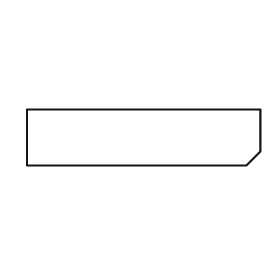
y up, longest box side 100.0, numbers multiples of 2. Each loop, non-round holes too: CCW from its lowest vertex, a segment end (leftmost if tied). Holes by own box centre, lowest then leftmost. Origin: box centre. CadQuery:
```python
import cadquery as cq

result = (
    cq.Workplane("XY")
    .moveTo(-50.0, -12.0)
    .lineTo(44.0, -12.0)
    .lineTo(50.0, -6.0)
    .lineTo(50.0, 12.0)
    .lineTo(-50.0, 12.0)
    .close()
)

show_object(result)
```